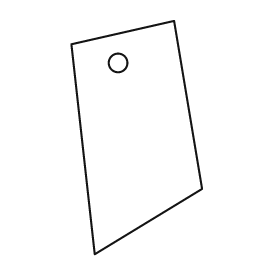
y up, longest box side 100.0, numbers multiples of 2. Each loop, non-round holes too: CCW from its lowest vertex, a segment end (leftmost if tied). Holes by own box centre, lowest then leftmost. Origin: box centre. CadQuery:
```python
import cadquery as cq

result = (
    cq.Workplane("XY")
    .moveTo(-18.0, -50.0)
    .lineTo(28.0, -22.0)
    .lineTo(16.0, 50.0)
    .lineTo(-28.0, 40.0)
    .close()
    .moveTo(-8.0, 32.0)
    .circle(4.0)
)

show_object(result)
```